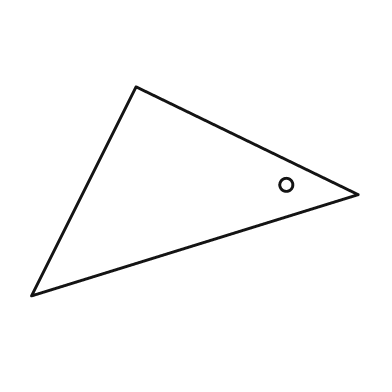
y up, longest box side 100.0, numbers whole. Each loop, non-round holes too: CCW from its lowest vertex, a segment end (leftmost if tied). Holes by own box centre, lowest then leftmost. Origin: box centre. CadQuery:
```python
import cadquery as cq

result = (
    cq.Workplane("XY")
    .moveTo(-50.0, -32.0)
    .lineTo(50.0, -1.0)
    .lineTo(-18.0, 32.0)
    .close()
    .moveTo(28.0, 2.0)
    .circle(2.0)
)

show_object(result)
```